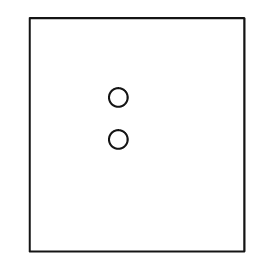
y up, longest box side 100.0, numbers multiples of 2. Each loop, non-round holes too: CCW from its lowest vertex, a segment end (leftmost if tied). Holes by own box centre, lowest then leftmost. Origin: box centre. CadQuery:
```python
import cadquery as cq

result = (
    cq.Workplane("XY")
    .moveTo(-46.0, -50.0)
    .lineTo(46.0, -50.0)
    .lineTo(46.0, 50.0)
    .lineTo(-46.0, 50.0)
    .close()
    .moveTo(-8.0, -2.0)
    .circle(4.0)
    .moveTo(-8.0, 16.0)
    .circle(4.0)
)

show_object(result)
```